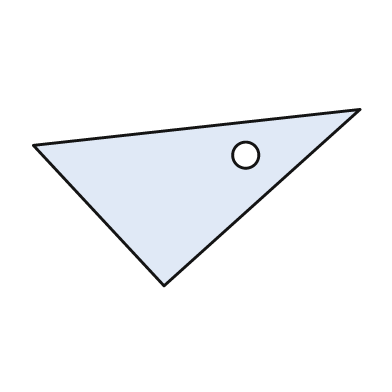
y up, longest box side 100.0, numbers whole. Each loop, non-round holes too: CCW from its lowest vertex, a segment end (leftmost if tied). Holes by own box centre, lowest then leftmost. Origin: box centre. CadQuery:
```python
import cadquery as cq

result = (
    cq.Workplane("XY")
    .moveTo(-10.0, -27.0)
    .lineTo(50.0, 27.0)
    .lineTo(-50.0, 16.0)
    .close()
    .moveTo(15.0, 13.0)
    .circle(4.0)
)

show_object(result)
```